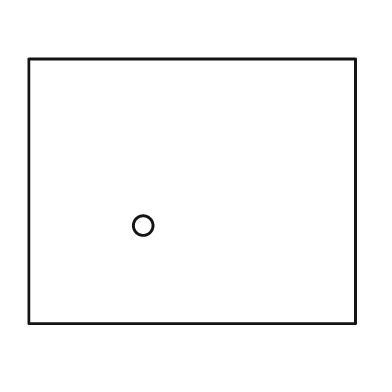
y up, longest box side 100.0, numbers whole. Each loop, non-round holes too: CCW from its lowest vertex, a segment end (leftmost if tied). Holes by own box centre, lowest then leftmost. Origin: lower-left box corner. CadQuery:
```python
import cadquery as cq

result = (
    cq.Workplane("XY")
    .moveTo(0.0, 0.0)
    .lineTo(100.0, 0.0)
    .lineTo(100.0, 81.0)
    .lineTo(0.0, 81.0)
    .close()
    .moveTo(35.0, 30.0)
    .circle(3.0)
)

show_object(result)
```